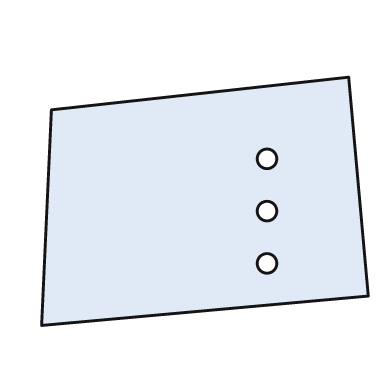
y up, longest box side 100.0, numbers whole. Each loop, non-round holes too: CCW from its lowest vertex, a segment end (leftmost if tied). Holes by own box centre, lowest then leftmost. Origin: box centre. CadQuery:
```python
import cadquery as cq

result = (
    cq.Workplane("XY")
    .moveTo(-50.0, -38.0)
    .lineTo(50.0, -29.0)
    .lineTo(44.0, 38.0)
    .lineTo(-47.0, 28.0)
    .close()
    .moveTo(19.0, -19.0)
    .circle(3.0)
    .moveTo(19.0, -3.0)
    .circle(3.0)
    .moveTo(19.0, 13.0)
    .circle(3.0)
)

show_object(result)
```